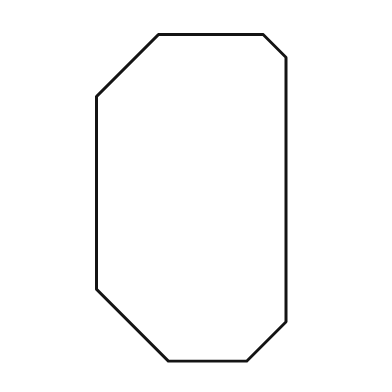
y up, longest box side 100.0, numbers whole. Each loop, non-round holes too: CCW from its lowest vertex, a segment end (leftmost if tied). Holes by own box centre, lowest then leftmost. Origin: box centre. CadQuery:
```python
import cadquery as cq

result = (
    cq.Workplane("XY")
    .moveTo(-7.0, -50.0)
    .lineTo(17.0, -50.0)
    .lineTo(29.0, -38.0)
    .lineTo(29.0, 43.0)
    .lineTo(22.0, 50.0)
    .lineTo(-10.0, 50.0)
    .lineTo(-29.0, 31.0)
    .lineTo(-29.0, -28.0)
    .close()
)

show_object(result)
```